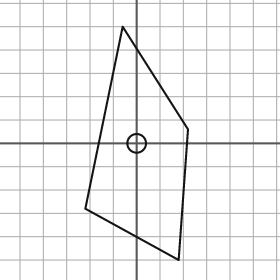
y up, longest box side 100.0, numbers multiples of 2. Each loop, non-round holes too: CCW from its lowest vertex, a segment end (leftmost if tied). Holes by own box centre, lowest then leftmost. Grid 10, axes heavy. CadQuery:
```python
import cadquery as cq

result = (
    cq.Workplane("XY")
    .moveTo(18.0, -50.0)
    .lineTo(22.0, 6.0)
    .lineTo(-6.0, 50.0)
    .lineTo(-22.0, -28.0)
    .close()
    .moveTo(0.0, 0.0)
    .circle(4.0)
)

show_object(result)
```